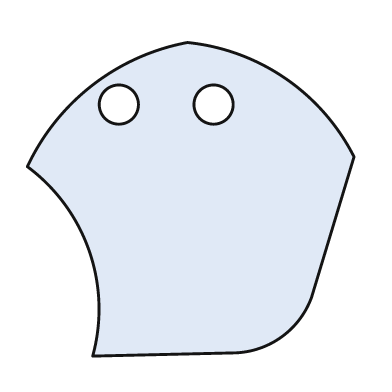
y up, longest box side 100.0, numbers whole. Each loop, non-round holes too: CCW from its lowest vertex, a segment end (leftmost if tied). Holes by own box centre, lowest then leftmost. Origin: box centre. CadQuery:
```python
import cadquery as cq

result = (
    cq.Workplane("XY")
    .moveTo(-30.0, -48.0)
    .lineTo(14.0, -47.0)
    .threePointArc((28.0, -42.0), (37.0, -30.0))
    .lineTo(50.0, 13.0)
    .threePointArc((29.0, 37.0), (-1.0, 48.0))
    .threePointArc((-30.0, 35.0), (-50.0, 10.0))
    .threePointArc((-31.0, -16.0), (-30.0, -48.0))
    .close()
    .moveTo(-22.0, 29.0)
    .circle(6.0)
    .moveTo(7.0, 29.0)
    .circle(6.0)
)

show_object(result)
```